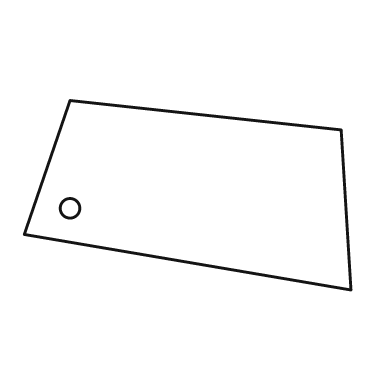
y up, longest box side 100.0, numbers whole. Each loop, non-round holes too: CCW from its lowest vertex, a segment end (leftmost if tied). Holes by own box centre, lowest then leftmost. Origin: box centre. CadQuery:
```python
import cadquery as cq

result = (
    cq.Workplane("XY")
    .moveTo(50.0, -29.0)
    .lineTo(47.0, 20.0)
    .lineTo(-36.0, 29.0)
    .lineTo(-50.0, -12.0)
    .close()
    .moveTo(-36.0, -4.0)
    .circle(3.0)
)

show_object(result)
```